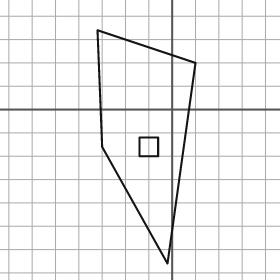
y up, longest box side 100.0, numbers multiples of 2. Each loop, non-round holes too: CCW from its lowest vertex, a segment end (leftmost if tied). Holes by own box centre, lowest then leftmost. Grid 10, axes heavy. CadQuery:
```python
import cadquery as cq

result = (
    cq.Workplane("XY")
    .moveTo(-2.0, -66.0)
    .lineTo(10.0, 20.0)
    .lineTo(-32.0, 34.0)
    .lineTo(-30.0, -16.0)
    .close()
    .moveTo(-14.0, -20.0)
    .lineTo(-6.0, -20.0)
    .lineTo(-6.0, -12.0)
    .lineTo(-14.0, -12.0)
    .close()
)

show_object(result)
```